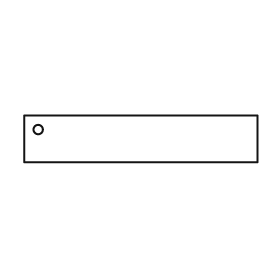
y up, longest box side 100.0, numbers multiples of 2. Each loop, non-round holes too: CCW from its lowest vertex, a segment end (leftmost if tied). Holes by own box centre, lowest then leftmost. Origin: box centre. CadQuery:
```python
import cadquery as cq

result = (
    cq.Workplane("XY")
    .moveTo(-50.0, -10.0)
    .lineTo(50.0, -10.0)
    .lineTo(50.0, 10.0)
    .lineTo(-50.0, 10.0)
    .close()
    .moveTo(-44.0, 4.0)
    .circle(2.0)
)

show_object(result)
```